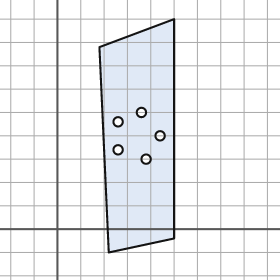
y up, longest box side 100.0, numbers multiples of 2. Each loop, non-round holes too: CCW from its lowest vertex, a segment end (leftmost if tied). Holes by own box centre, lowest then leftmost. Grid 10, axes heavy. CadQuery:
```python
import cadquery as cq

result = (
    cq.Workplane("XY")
    .moveTo(22.0, -10.0)
    .lineTo(50.0, -4.0)
    .lineTo(50.0, 90.0)
    .lineTo(18.0, 78.0)
    .close()
    .moveTo(38.0, 30.0)
    .circle(2.0)
    .moveTo(26.0, 34.0)
    .circle(2.0)
    .moveTo(44.0, 40.0)
    .circle(2.0)
    .moveTo(26.0, 46.0)
    .circle(2.0)
    .moveTo(36.0, 50.0)
    .circle(2.0)
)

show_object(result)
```